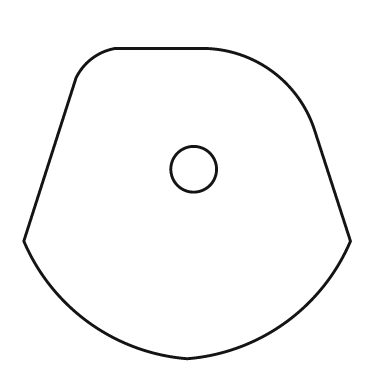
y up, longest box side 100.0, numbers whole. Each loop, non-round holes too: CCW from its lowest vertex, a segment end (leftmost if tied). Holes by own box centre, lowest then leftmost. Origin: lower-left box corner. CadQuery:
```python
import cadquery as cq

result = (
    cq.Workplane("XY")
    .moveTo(50.0, 0.0)
    .threePointArc((80.0, 11.0), (100.0, 36.0))
    .lineTo(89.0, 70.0)
    .threePointArc((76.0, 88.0), (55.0, 95.0))
    .lineTo(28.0, 95.0)
    .threePointArc((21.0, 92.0), (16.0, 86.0))
    .lineTo(0.0, 36.0)
    .threePointArc((20.0, 11.0), (50.0, 0.0))
    .close()
    .moveTo(52.0, 58.0)
    .circle(7.0)
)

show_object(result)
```